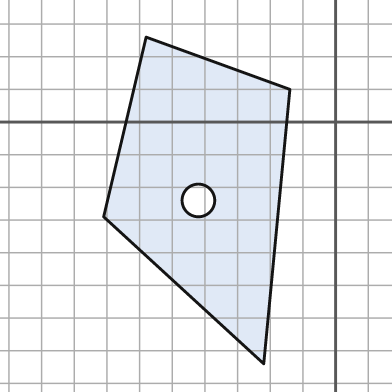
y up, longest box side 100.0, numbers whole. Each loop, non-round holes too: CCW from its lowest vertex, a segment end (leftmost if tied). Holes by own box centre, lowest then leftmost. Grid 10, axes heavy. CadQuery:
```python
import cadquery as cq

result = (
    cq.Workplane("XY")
    .moveTo(-22.0, -74.0)
    .lineTo(-14.0, 10.0)
    .lineTo(-58.0, 26.0)
    .lineTo(-71.0, -29.0)
    .close()
    .moveTo(-42.0, -24.0)
    .circle(5.0)
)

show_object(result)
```